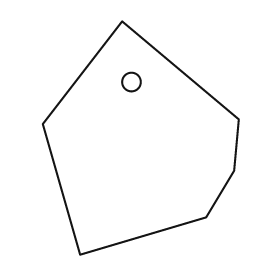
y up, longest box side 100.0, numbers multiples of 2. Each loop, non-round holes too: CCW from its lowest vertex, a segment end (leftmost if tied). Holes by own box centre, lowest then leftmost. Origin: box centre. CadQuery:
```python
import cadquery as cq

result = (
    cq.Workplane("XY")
    .moveTo(-26.0, -50.0)
    .lineTo(28.0, -34.0)
    .lineTo(40.0, -14.0)
    .lineTo(42.0, 8.0)
    .lineTo(-8.0, 50.0)
    .lineTo(-42.0, 6.0)
    .close()
    .moveTo(-4.0, 24.0)
    .circle(4.0)
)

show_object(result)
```